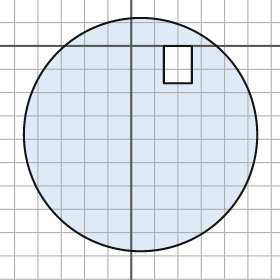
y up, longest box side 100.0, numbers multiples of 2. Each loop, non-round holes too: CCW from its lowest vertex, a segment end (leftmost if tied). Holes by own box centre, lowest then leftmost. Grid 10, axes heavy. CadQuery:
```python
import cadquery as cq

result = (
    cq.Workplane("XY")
    .moveTo(4.0, -38.0)
    .circle(50.0)
    .moveTo(14.0, -16.0)
    .lineTo(26.0, -16.0)
    .lineTo(26.0, 0.0)
    .lineTo(14.0, 0.0)
    .close()
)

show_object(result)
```